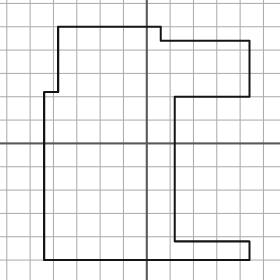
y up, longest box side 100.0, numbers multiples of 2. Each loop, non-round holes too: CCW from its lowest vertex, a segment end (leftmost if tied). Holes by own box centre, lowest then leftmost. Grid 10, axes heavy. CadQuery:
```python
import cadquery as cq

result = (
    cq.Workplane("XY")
    .moveTo(-44.0, -50.0)
    .lineTo(44.0, -50.0)
    .lineTo(44.0, -42.0)
    .lineTo(12.0, -42.0)
    .lineTo(12.0, 20.0)
    .lineTo(44.0, 20.0)
    .lineTo(44.0, 44.0)
    .lineTo(6.0, 44.0)
    .lineTo(6.0, 50.0)
    .lineTo(-38.0, 50.0)
    .lineTo(-38.0, 22.0)
    .lineTo(-44.0, 22.0)
    .close()
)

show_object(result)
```